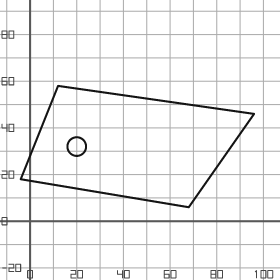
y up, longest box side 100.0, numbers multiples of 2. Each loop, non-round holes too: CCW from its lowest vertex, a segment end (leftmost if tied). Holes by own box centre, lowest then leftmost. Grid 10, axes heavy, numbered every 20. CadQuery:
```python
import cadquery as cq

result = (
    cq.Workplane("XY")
    .moveTo(68.0, 6.0)
    .lineTo(96.0, 46.0)
    .lineTo(12.0, 58.0)
    .lineTo(-4.0, 18.0)
    .close()
    .moveTo(20.0, 32.0)
    .circle(4.0)
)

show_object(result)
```